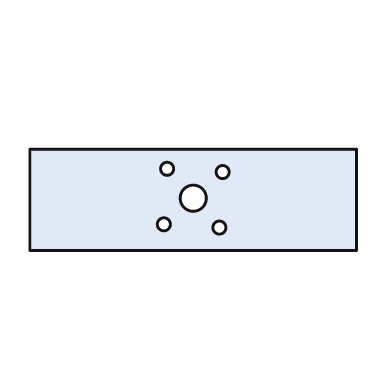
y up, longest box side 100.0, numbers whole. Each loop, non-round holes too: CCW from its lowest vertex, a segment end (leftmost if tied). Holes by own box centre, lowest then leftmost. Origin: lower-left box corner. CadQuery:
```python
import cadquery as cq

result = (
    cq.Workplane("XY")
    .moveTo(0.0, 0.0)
    .lineTo(100.0, 0.0)
    .lineTo(100.0, 31.0)
    .lineTo(0.0, 31.0)
    .close()
    .moveTo(58.0, 7.0)
    .circle(2.0)
    .moveTo(41.0, 8.0)
    .circle(2.0)
    .moveTo(50.0, 16.0)
    .circle(4.0)
    .moveTo(59.0, 24.0)
    .circle(2.0)
    .moveTo(42.0, 25.0)
    .circle(2.0)
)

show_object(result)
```